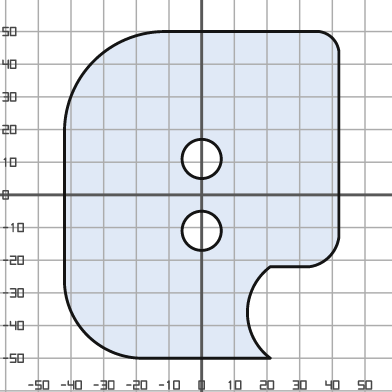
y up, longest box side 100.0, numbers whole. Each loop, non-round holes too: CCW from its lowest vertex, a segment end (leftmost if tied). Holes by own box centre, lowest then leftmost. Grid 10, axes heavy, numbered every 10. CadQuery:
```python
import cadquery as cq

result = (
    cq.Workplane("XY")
    .moveTo(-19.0, -50.0)
    .lineTo(21.0, -50.0)
    .threePointArc((14.0, -36.0), (21.0, -22.0))
    .lineTo(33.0, -22.0)
    .threePointArc((39.0, -19.0), (42.0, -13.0))
    .lineTo(42.0, 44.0)
    .threePointArc((40.0, 48.0), (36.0, 50.0))
    .lineTo(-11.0, 50.0)
    .threePointArc((-33.0, 41.0), (-42.0, 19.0))
    .lineTo(-42.0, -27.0)
    .threePointArc((-35.0, -43.0), (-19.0, -50.0))
    .close()
    .moveTo(0.0, -11.0)
    .circle(6.0)
    .moveTo(0.0, 11.0)
    .circle(6.0)
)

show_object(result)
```